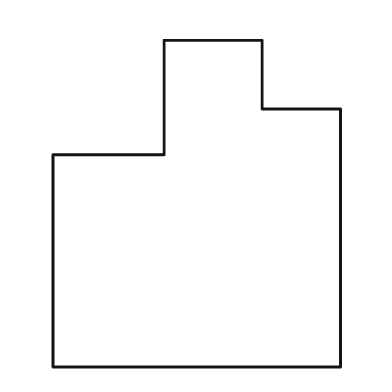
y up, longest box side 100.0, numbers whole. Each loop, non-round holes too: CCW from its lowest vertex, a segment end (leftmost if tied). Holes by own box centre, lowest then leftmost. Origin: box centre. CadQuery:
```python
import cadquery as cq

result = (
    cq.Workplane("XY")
    .moveTo(-44.0, -50.0)
    .lineTo(44.0, -50.0)
    .lineTo(44.0, 29.0)
    .lineTo(20.0, 29.0)
    .lineTo(20.0, 50.0)
    .lineTo(-10.0, 50.0)
    .lineTo(-10.0, 15.0)
    .lineTo(-44.0, 15.0)
    .close()
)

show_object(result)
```